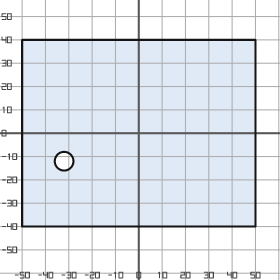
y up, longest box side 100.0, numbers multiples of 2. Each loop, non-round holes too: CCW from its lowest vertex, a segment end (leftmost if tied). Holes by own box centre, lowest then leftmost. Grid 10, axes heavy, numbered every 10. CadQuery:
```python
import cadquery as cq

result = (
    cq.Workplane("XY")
    .moveTo(-50.0, -40.0)
    .lineTo(50.0, -40.0)
    .lineTo(50.0, 40.0)
    .lineTo(-50.0, 40.0)
    .close()
    .moveTo(-32.0, -12.0)
    .circle(4.0)
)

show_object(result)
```